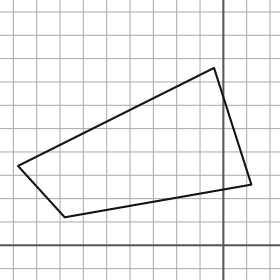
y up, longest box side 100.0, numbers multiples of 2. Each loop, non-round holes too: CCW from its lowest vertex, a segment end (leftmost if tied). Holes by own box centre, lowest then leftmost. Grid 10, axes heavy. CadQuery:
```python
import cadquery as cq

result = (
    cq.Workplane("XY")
    .moveTo(-68.0, 12.0)
    .lineTo(12.0, 26.0)
    .lineTo(-4.0, 76.0)
    .lineTo(-88.0, 34.0)
    .close()
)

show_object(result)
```